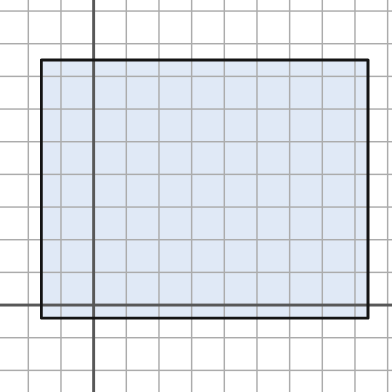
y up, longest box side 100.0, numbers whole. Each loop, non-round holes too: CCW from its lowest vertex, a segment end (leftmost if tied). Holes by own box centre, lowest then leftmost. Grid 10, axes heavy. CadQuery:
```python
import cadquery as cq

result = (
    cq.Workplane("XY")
    .moveTo(-16.0, -4.0)
    .lineTo(84.0, -4.0)
    .lineTo(84.0, 75.0)
    .lineTo(-16.0, 75.0)
    .close()
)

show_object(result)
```